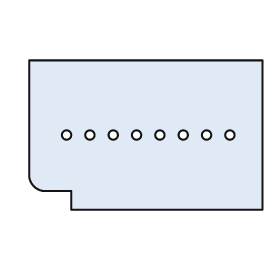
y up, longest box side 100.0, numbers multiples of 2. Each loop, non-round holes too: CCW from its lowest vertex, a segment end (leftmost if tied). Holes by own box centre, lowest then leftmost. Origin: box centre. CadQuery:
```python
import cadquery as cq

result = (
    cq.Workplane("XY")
    .moveTo(-32.0, -32.0)
    .lineTo(50.0, -32.0)
    .lineTo(50.0, 32.0)
    .lineTo(-50.0, 32.0)
    .lineTo(-50.0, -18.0)
    .threePointArc((-48.0, -22.0), (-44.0, -24.0))
    .lineTo(-32.0, -24.0)
    .close()
    .moveTo(-34.0, 0.0)
    .circle(2.0)
    .moveTo(-24.0, 0.0)
    .circle(2.0)
    .moveTo(-14.0, 0.0)
    .circle(2.0)
    .moveTo(-4.0, 0.0)
    .circle(2.0)
    .moveTo(6.0, 0.0)
    .circle(2.0)
    .moveTo(16.0, 0.0)
    .circle(2.0)
    .moveTo(26.0, 0.0)
    .circle(2.0)
    .moveTo(36.0, 0.0)
    .circle(2.0)
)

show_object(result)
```